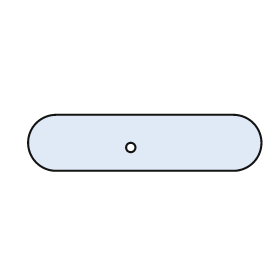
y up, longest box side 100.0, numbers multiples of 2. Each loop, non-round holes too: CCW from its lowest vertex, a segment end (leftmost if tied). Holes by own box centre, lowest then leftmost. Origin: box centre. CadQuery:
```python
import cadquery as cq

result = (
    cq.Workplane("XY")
    .moveTo(-38.0, -12.0)
    .lineTo(38.0, -12.0)
    .threePointArc((50.0, 0.0), (38.0, 12.0))
    .lineTo(-38.0, 12.0)
    .threePointArc((-50.0, 0.0), (-38.0, -12.0))
    .close()
    .moveTo(-6.0, -2.0)
    .circle(2.0)
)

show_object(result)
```